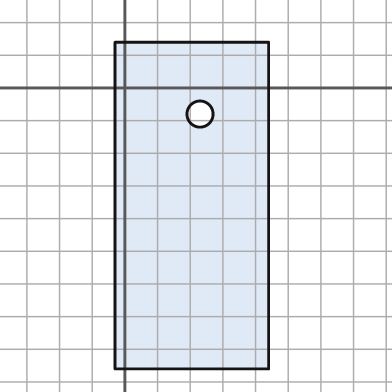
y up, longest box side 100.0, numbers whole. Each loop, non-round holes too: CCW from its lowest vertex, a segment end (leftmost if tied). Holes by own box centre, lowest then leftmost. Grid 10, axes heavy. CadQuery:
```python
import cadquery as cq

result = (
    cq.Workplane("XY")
    .moveTo(-3.0, -86.0)
    .lineTo(44.0, -86.0)
    .lineTo(44.0, 14.0)
    .lineTo(-3.0, 14.0)
    .close()
    .moveTo(23.0, -8.0)
    .circle(4.0)
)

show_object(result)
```